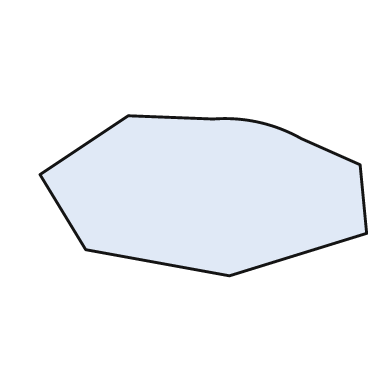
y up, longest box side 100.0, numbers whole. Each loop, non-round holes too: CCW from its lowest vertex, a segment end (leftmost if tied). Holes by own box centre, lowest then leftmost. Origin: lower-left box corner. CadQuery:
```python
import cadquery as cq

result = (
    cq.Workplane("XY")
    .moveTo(58.0, 0.0)
    .lineTo(100.0, 13.0)
    .lineTo(98.0, 34.0)
    .lineTo(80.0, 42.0)
    .threePointArc((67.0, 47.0), (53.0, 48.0))
    .lineTo(27.0, 49.0)
    .lineTo(0.0, 31.0)
    .lineTo(14.0, 8.0)
    .close()
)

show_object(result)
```